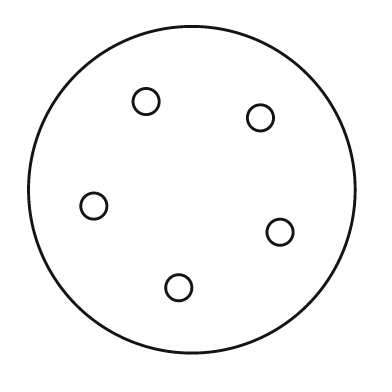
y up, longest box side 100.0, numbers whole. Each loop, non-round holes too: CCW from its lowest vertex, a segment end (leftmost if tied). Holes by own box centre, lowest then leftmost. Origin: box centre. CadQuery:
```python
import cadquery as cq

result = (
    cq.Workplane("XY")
    .moveTo(0.0, 0.0)
    .circle(50.0)
    .moveTo(-4.0, -30.0)
    .circle(4.0)
    .moveTo(27.0, -13.0)
    .circle(4.0)
    .moveTo(-30.0, -5.0)
    .circle(4.0)
    .moveTo(21.0, 22.0)
    .circle(4.0)
    .moveTo(-14.0, 27.0)
    .circle(4.0)
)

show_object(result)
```